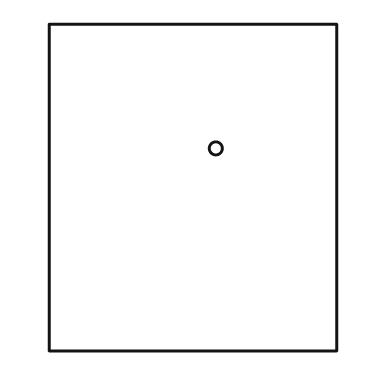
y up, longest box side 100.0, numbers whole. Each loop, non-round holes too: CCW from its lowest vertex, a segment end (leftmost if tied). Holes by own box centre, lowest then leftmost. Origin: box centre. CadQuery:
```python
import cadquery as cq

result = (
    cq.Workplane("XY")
    .moveTo(-44.0, -50.0)
    .lineTo(44.0, -50.0)
    .lineTo(44.0, 50.0)
    .lineTo(-44.0, 50.0)
    .close()
    .moveTo(7.0, 12.0)
    .circle(2.0)
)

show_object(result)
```